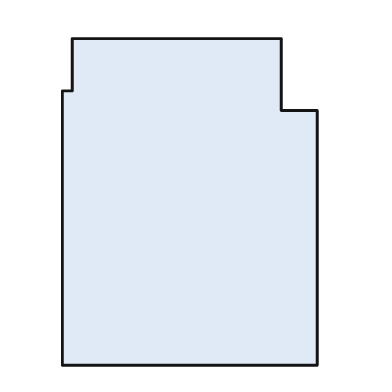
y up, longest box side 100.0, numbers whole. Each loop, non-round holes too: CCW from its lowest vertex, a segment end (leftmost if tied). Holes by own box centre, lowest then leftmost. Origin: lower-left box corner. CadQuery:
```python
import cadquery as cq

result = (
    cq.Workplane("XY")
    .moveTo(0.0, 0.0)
    .lineTo(78.0, 0.0)
    .lineTo(78.0, 78.0)
    .lineTo(67.0, 78.0)
    .lineTo(67.0, 100.0)
    .lineTo(3.0, 100.0)
    .lineTo(3.0, 84.0)
    .lineTo(0.0, 84.0)
    .close()
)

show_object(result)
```